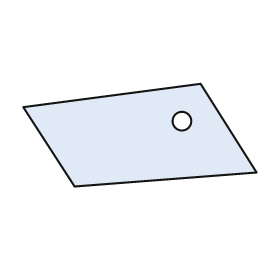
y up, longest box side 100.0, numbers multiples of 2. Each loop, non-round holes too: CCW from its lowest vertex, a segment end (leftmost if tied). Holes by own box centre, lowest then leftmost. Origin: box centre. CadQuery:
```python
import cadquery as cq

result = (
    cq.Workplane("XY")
    .moveTo(-28.0, -22.0)
    .lineTo(50.0, -16.0)
    .lineTo(26.0, 22.0)
    .lineTo(-50.0, 12.0)
    .close()
    .moveTo(18.0, 6.0)
    .circle(4.0)
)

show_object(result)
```